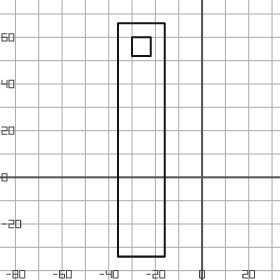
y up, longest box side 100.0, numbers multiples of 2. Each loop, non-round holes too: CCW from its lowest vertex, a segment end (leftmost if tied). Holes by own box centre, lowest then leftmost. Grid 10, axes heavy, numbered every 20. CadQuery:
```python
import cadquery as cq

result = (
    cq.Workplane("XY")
    .moveTo(-36.0, -34.0)
    .lineTo(-16.0, -34.0)
    .lineTo(-16.0, 66.0)
    .lineTo(-36.0, 66.0)
    .close()
    .moveTo(-30.0, 52.0)
    .lineTo(-22.0, 52.0)
    .lineTo(-22.0, 60.0)
    .lineTo(-30.0, 60.0)
    .close()
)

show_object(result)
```